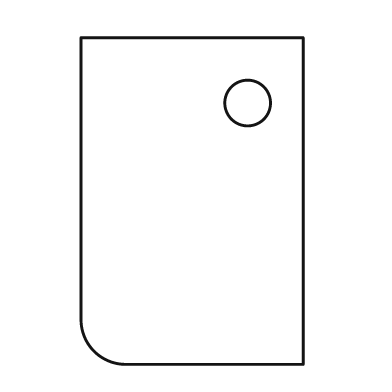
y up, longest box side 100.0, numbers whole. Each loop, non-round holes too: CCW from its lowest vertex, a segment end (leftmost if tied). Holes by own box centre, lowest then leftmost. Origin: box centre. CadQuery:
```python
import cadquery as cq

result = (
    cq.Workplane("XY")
    .moveTo(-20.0, -50.0)
    .lineTo(34.0, -50.0)
    .lineTo(34.0, 50.0)
    .lineTo(-34.0, 50.0)
    .lineTo(-34.0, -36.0)
    .threePointArc((-30.0, -46.0), (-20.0, -50.0))
    .close()
    .moveTo(17.0, 30.0)
    .circle(7.0)
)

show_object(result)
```